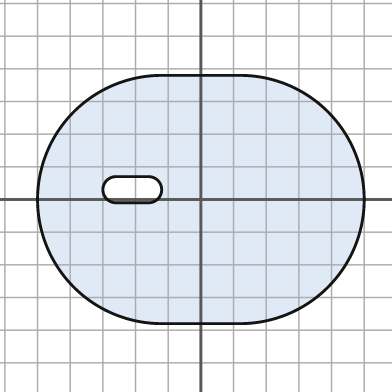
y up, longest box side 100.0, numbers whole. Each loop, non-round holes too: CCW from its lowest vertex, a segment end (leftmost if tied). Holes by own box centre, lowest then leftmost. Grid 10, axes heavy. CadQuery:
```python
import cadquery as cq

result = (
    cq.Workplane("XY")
    .moveTo(-12.0, -38.0)
    .lineTo(12.0, -38.0)
    .threePointArc((50.0, 0.0), (12.0, 38.0))
    .lineTo(-12.0, 38.0)
    .threePointArc((-50.0, 0.0), (-12.0, -38.0))
    .close()
    .moveTo(-26.0, -1.0)
    .lineTo(-16.0, -1.0)
    .threePointArc((-12.0, 3.0), (-16.0, 7.0))
    .lineTo(-26.0, 7.0)
    .threePointArc((-30.0, 3.0), (-26.0, -1.0))
    .close()
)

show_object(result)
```